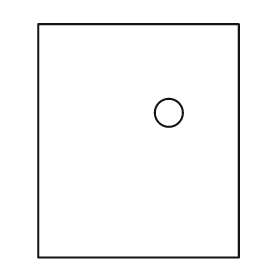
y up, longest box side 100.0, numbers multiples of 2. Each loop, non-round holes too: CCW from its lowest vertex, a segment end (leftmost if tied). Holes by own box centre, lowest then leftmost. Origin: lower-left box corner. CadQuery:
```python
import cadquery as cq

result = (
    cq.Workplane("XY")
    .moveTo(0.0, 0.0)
    .lineTo(86.0, 0.0)
    .lineTo(86.0, 100.0)
    .lineTo(0.0, 100.0)
    .close()
    .moveTo(56.0, 62.0)
    .circle(6.0)
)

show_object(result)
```